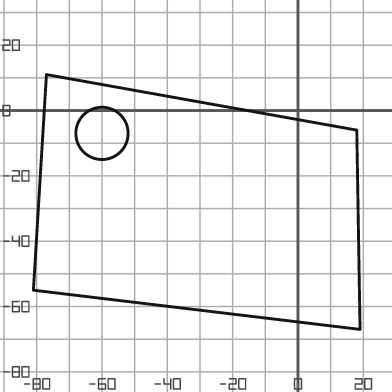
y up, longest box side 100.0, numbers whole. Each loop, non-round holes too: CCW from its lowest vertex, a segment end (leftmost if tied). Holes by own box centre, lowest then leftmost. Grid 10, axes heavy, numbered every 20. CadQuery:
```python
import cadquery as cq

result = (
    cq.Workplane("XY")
    .moveTo(19.0, -67.0)
    .lineTo(18.0, -6.0)
    .lineTo(-77.0, 11.0)
    .lineTo(-81.0, -55.0)
    .close()
    .moveTo(-60.0, -7.0)
    .circle(8.0)
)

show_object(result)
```